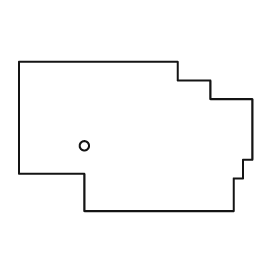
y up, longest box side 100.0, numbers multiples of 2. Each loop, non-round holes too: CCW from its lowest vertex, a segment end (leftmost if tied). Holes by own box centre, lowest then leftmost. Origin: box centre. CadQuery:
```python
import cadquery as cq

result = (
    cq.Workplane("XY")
    .moveTo(-22.0, -32.0)
    .lineTo(42.0, -32.0)
    .lineTo(42.0, -18.0)
    .lineTo(46.0, -18.0)
    .lineTo(46.0, -10.0)
    .lineTo(50.0, -10.0)
    .lineTo(50.0, 16.0)
    .lineTo(32.0, 16.0)
    .lineTo(32.0, 24.0)
    .lineTo(18.0, 24.0)
    .lineTo(18.0, 32.0)
    .lineTo(-50.0, 32.0)
    .lineTo(-50.0, -16.0)
    .lineTo(-22.0, -16.0)
    .close()
    .moveTo(-22.0, -4.0)
    .circle(2.0)
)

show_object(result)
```